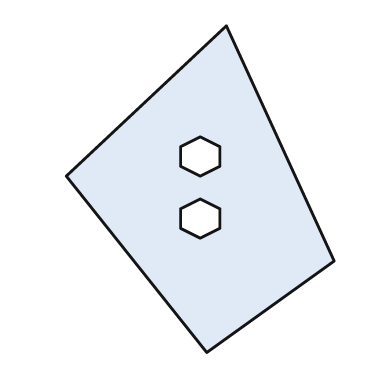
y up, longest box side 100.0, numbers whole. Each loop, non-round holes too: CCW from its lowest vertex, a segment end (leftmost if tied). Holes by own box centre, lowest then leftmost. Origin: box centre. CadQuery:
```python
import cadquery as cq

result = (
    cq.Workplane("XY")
    .moveTo(2.0, -50.0)
    .lineTo(41.0, -22.0)
    .lineTo(8.0, 50.0)
    .lineTo(-41.0, 4.0)
    .close()
    .moveTo(0.0, -15.0)
    .lineTo(6.0, -12.0)
    .lineTo(6.0, -6.0)
    .lineTo(0.0, -3.0)
    .lineTo(-6.0, -6.0)
    .lineTo(-6.0, -12.0)
    .close()
    .moveTo(0.0, 4.0)
    .lineTo(6.0, 7.0)
    .lineTo(6.0, 13.0)
    .lineTo(0.0, 16.0)
    .lineTo(-6.0, 13.0)
    .lineTo(-6.0, 7.0)
    .close()
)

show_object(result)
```